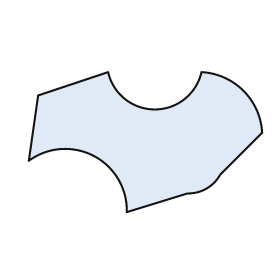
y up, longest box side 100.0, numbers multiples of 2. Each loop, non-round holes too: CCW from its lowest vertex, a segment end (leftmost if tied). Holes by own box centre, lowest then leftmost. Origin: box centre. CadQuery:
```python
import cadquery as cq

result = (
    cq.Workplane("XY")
    .moveTo(-8.0, -30.0)
    .lineTo(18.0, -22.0)
    .threePointArc((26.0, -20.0), (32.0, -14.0))
    .lineTo(50.0, 4.0)
    .threePointArc((42.0, 22.0), (24.0, 30.0))
    .threePointArc((4.0, 14.0), (-16.0, 30.0))
    .lineTo(-46.0, 20.0)
    .lineTo(-50.0, -8.0)
    .threePointArc((-22.0, -6.0), (-8.0, -30.0))
    .close()
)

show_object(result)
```